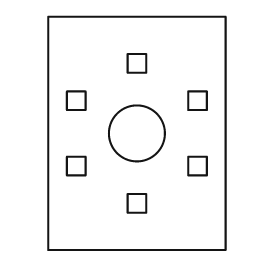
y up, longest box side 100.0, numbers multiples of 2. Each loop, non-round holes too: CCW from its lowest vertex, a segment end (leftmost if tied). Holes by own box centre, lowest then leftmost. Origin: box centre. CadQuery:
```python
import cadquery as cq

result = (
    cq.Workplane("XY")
    .moveTo(-38.0, -50.0)
    .lineTo(38.0, -50.0)
    .lineTo(38.0, 50.0)
    .lineTo(-38.0, 50.0)
    .close()
    .moveTo(-4.0, -34.0)
    .lineTo(4.0, -34.0)
    .lineTo(4.0, -26.0)
    .lineTo(-4.0, -26.0)
    .close()
    .moveTo(-30.0, -18.0)
    .lineTo(-22.0, -18.0)
    .lineTo(-22.0, -10.0)
    .lineTo(-30.0, -10.0)
    .close()
    .moveTo(22.0, -18.0)
    .lineTo(30.0, -18.0)
    .lineTo(30.0, -10.0)
    .lineTo(22.0, -10.0)
    .close()
    .moveTo(0.0, 0.0)
    .circle(12.0)
    .moveTo(-30.0, 10.0)
    .lineTo(-22.0, 10.0)
    .lineTo(-22.0, 18.0)
    .lineTo(-30.0, 18.0)
    .close()
    .moveTo(22.0, 10.0)
    .lineTo(30.0, 10.0)
    .lineTo(30.0, 18.0)
    .lineTo(22.0, 18.0)
    .close()
    .moveTo(-4.0, 26.0)
    .lineTo(4.0, 26.0)
    .lineTo(4.0, 34.0)
    .lineTo(-4.0, 34.0)
    .close()
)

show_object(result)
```